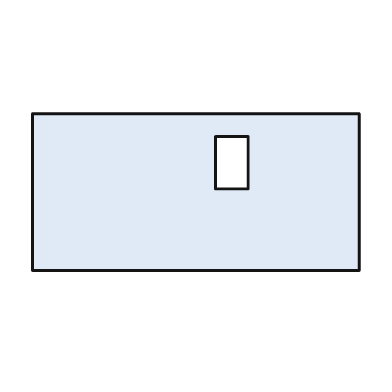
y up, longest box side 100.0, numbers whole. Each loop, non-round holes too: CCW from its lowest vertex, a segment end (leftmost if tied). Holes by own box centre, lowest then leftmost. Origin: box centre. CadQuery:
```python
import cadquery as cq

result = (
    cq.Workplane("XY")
    .moveTo(-50.0, -24.0)
    .lineTo(50.0, -24.0)
    .lineTo(50.0, 24.0)
    .lineTo(-50.0, 24.0)
    .close()
    .moveTo(6.0, 1.0)
    .lineTo(16.0, 1.0)
    .lineTo(16.0, 17.0)
    .lineTo(6.0, 17.0)
    .close()
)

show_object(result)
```